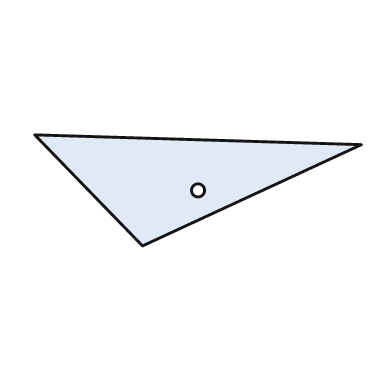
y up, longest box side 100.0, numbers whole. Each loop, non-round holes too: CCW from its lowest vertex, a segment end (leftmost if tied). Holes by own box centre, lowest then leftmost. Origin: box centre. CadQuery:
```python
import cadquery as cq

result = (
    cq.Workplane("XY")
    .moveTo(-17.0, -17.0)
    .lineTo(50.0, 14.0)
    .lineTo(-50.0, 17.0)
    .close()
    .moveTo(0.0, 0.0)
    .circle(2.0)
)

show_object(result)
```